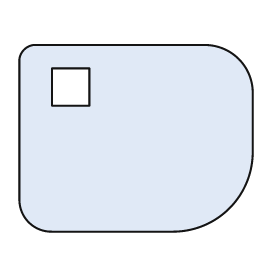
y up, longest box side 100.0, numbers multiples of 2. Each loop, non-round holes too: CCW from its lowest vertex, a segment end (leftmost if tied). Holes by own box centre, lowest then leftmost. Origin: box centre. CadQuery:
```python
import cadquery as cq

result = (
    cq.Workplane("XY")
    .moveTo(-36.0, -40.0)
    .lineTo(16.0, -40.0)
    .threePointArc((40.0, -30.0), (50.0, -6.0))
    .lineTo(50.0, 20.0)
    .threePointArc((44.0, 34.0), (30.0, 40.0))
    .lineTo(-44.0, 40.0)
    .threePointArc((-48.0, 38.0), (-50.0, 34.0))
    .lineTo(-50.0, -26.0)
    .threePointArc((-46.0, -36.0), (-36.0, -40.0))
    .close()
    .moveTo(-36.0, 14.0)
    .lineTo(-20.0, 14.0)
    .lineTo(-20.0, 30.0)
    .lineTo(-36.0, 30.0)
    .close()
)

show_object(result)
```